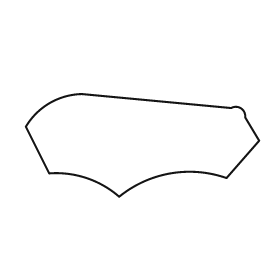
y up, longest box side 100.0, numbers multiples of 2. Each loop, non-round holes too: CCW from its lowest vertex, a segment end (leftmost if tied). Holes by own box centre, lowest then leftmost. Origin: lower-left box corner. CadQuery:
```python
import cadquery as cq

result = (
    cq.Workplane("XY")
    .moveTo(40.0, 0.0)
    .threePointArc((62.0, 10.0), (86.0, 8.0))
    .lineTo(100.0, 24.0)
    .lineTo(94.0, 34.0)
    .threePointArc((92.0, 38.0), (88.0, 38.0))
    .lineTo(24.0, 44.0)
    .threePointArc((10.0, 40.0), (0.0, 30.0))
    .lineTo(10.0, 10.0)
    .threePointArc((26.0, 8.0), (40.0, 0.0))
    .close()
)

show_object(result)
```